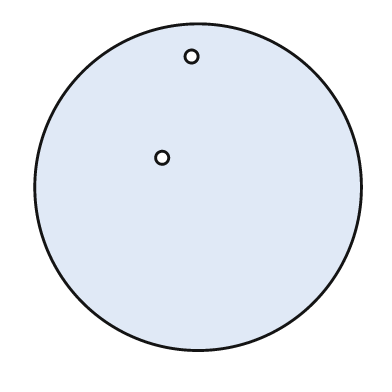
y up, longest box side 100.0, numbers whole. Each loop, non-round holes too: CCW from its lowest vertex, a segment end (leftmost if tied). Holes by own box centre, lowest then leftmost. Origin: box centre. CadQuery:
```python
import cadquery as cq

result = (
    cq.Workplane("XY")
    .moveTo(0.0, 0.0)
    .circle(50.0)
    .moveTo(-11.0, 9.0)
    .circle(2.0)
    .moveTo(-2.0, 40.0)
    .circle(2.0)
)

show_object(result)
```